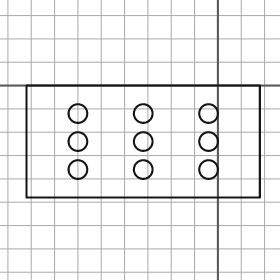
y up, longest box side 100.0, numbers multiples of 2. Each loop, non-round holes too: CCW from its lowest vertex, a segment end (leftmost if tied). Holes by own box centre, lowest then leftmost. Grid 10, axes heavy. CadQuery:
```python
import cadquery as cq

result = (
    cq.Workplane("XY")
    .moveTo(-82.0, -48.0)
    .lineTo(18.0, -48.0)
    .lineTo(18.0, 0.0)
    .lineTo(-82.0, 0.0)
    .close()
    .moveTo(-60.0, -36.0)
    .circle(4.0)
    .moveTo(-32.0, -36.0)
    .circle(4.0)
    .moveTo(-4.0, -36.0)
    .circle(4.0)
    .moveTo(-60.0, -24.0)
    .circle(4.0)
    .moveTo(-32.0, -24.0)
    .circle(4.0)
    .moveTo(-4.0, -24.0)
    .circle(4.0)
    .moveTo(-60.0, -12.0)
    .circle(4.0)
    .moveTo(-32.0, -12.0)
    .circle(4.0)
    .moveTo(-4.0, -12.0)
    .circle(4.0)
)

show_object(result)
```